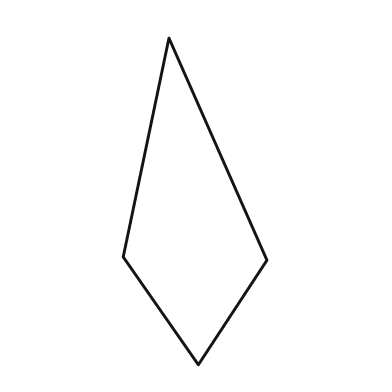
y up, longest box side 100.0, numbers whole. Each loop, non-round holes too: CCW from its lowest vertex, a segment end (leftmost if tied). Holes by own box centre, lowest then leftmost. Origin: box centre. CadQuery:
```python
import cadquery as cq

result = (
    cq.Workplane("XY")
    .moveTo(1.0, -50.0)
    .lineTo(22.0, -18.0)
    .lineTo(-8.0, 50.0)
    .lineTo(-22.0, -17.0)
    .close()
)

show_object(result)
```